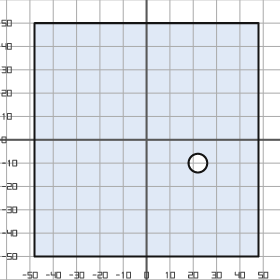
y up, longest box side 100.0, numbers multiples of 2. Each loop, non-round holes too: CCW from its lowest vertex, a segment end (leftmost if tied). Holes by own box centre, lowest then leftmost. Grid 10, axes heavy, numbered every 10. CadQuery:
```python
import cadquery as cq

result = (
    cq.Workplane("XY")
    .moveTo(-48.0, -50.0)
    .lineTo(48.0, -50.0)
    .lineTo(48.0, 50.0)
    .lineTo(-48.0, 50.0)
    .close()
    .moveTo(22.0, -10.0)
    .circle(4.0)
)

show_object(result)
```